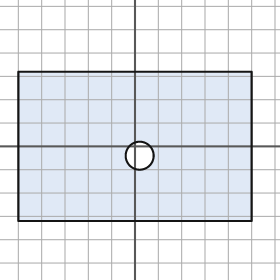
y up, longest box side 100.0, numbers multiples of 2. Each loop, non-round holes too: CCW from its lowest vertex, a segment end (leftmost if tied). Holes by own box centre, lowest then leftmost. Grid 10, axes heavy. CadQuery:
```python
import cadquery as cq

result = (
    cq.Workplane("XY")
    .moveTo(-50.0, -32.0)
    .lineTo(50.0, -32.0)
    .lineTo(50.0, 32.0)
    .lineTo(-50.0, 32.0)
    .close()
    .moveTo(2.0, -4.0)
    .circle(6.0)
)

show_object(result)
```